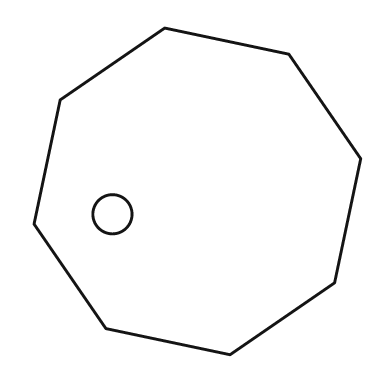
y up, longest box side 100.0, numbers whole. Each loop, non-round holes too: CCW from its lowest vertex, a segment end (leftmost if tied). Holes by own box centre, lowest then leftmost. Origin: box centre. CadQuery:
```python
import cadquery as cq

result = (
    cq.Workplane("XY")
    .moveTo(10.0, -50.0)
    .lineTo(42.0, -28.0)
    .lineTo(50.0, 10.0)
    .lineTo(28.0, 42.0)
    .lineTo(-10.0, 50.0)
    .lineTo(-42.0, 28.0)
    .lineTo(-50.0, -10.0)
    .lineTo(-28.0, -42.0)
    .close()
    .moveTo(-26.0, -7.0)
    .circle(6.0)
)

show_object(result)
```